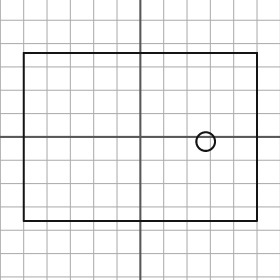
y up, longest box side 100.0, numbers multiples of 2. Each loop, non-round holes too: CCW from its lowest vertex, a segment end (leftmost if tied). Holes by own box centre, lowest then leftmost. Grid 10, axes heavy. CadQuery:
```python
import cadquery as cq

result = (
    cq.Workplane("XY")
    .moveTo(-50.0, -36.0)
    .lineTo(50.0, -36.0)
    .lineTo(50.0, 36.0)
    .lineTo(-50.0, 36.0)
    .close()
    .moveTo(28.0, -2.0)
    .circle(4.0)
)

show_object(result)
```